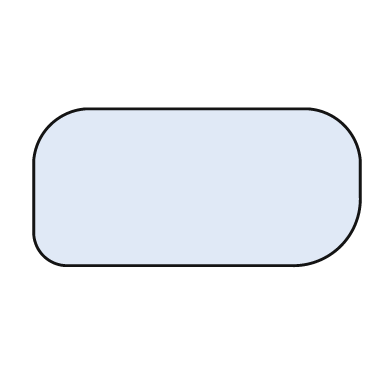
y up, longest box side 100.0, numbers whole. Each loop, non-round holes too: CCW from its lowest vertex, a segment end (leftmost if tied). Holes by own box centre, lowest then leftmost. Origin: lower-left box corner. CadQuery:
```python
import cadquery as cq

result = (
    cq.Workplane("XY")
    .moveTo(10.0, 0.0)
    .lineTo(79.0, 0.0)
    .threePointArc((94.0, 6.0), (100.0, 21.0))
    .lineTo(100.0, 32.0)
    .threePointArc((95.0, 43.0), (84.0, 48.0))
    .lineTo(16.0, 48.0)
    .threePointArc((5.0, 43.0), (0.0, 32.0))
    .lineTo(0.0, 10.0)
    .threePointArc((3.0, 3.0), (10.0, 0.0))
    .close()
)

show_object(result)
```